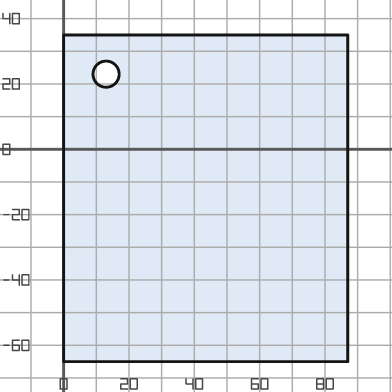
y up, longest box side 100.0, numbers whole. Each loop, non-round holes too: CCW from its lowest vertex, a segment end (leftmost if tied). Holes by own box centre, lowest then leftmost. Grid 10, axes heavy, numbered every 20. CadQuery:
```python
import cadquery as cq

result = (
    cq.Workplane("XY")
    .moveTo(0.0, -65.0)
    .lineTo(87.0, -65.0)
    .lineTo(87.0, 35.0)
    .lineTo(0.0, 35.0)
    .close()
    .moveTo(13.0, 23.0)
    .circle(4.0)
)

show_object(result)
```